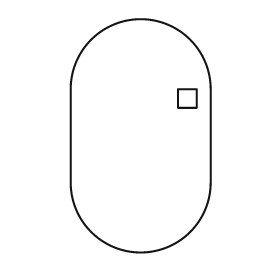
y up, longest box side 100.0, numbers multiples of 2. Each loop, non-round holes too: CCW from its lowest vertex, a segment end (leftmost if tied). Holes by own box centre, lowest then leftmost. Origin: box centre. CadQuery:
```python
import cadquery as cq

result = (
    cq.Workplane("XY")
    .moveTo(-30.0, -20.0)
    .threePointArc((0.0, -50.0), (30.0, -20.0))
    .lineTo(30.0, 20.0)
    .threePointArc((0.0, 50.0), (-30.0, 20.0))
    .close()
    .moveTo(16.0, 12.0)
    .lineTo(24.0, 12.0)
    .lineTo(24.0, 20.0)
    .lineTo(16.0, 20.0)
    .close()
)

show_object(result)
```